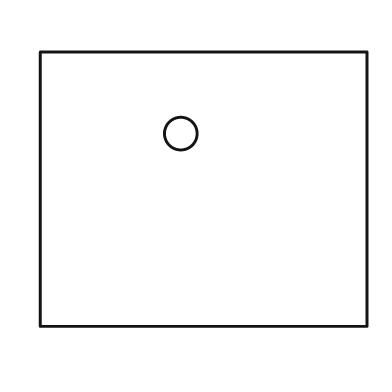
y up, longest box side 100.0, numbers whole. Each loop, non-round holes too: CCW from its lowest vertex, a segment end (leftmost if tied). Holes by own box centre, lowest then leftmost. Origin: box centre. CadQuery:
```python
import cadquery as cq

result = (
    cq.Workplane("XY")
    .moveTo(-50.0, -42.0)
    .lineTo(50.0, -42.0)
    .lineTo(50.0, 42.0)
    .lineTo(-50.0, 42.0)
    .close()
    .moveTo(-7.0, 17.0)
    .circle(5.0)
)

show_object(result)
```